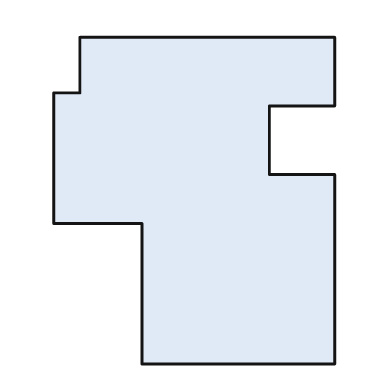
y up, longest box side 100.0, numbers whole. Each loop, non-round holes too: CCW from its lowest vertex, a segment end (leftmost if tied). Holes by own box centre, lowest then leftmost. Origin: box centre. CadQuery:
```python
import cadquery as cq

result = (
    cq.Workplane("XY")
    .moveTo(-16.0, -50.0)
    .lineTo(43.0, -50.0)
    .lineTo(43.0, 8.0)
    .lineTo(23.0, 8.0)
    .lineTo(23.0, 29.0)
    .lineTo(43.0, 29.0)
    .lineTo(43.0, 50.0)
    .lineTo(-35.0, 50.0)
    .lineTo(-35.0, 33.0)
    .lineTo(-43.0, 33.0)
    .lineTo(-43.0, -7.0)
    .lineTo(-16.0, -7.0)
    .close()
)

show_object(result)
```